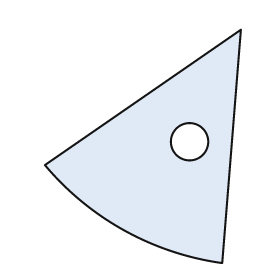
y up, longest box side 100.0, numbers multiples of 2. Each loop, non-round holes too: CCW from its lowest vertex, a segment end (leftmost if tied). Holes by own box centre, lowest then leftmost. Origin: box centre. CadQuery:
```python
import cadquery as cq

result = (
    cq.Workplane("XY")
    .moveTo(34.0, -50.0)
    .lineTo(42.0, 50.0)
    .lineTo(-42.0, -8.0)
    .threePointArc((-8.0, -36.0), (34.0, -50.0))
    .close()
    .moveTo(20.0, 2.0)
    .circle(8.0)
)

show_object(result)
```